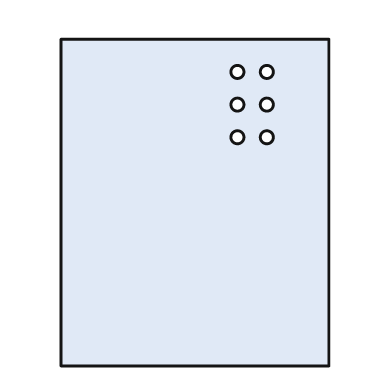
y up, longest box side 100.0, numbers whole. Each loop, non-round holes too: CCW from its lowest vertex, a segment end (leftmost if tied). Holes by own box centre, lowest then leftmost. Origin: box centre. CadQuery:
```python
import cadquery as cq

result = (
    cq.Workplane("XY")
    .moveTo(-41.0, -50.0)
    .lineTo(41.0, -50.0)
    .lineTo(41.0, 50.0)
    .lineTo(-41.0, 50.0)
    .close()
    .moveTo(13.0, 20.0)
    .circle(2.0)
    .moveTo(22.0, 20.0)
    .circle(2.0)
    .moveTo(13.0, 30.0)
    .circle(2.0)
    .moveTo(22.0, 30.0)
    .circle(2.0)
    .moveTo(13.0, 40.0)
    .circle(2.0)
    .moveTo(22.0, 40.0)
    .circle(2.0)
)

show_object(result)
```